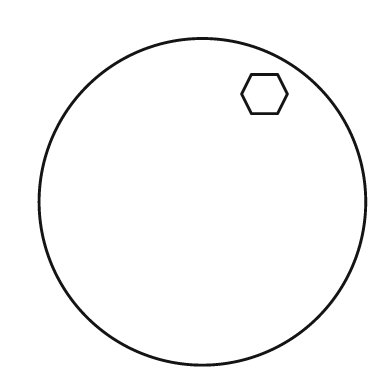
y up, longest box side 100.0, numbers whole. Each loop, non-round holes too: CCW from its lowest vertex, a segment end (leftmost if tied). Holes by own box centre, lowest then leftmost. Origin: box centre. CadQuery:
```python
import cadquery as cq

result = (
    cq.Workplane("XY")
    .moveTo(0.0, 0.0)
    .circle(50.0)
    .moveTo(15.0, 27.0)
    .lineTo(23.0, 27.0)
    .lineTo(26.0, 33.0)
    .lineTo(23.0, 39.0)
    .lineTo(15.0, 39.0)
    .lineTo(12.0, 33.0)
    .close()
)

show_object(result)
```